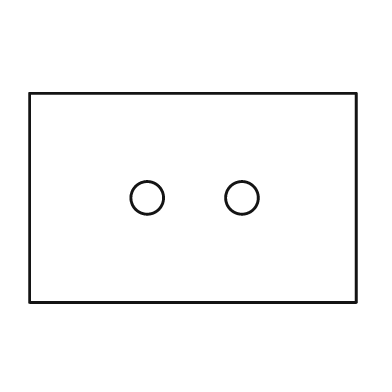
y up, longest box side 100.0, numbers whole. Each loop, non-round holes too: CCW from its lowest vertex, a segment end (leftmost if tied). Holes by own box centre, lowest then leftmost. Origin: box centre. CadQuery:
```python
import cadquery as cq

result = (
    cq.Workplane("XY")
    .moveTo(-50.0, -32.0)
    .lineTo(50.0, -32.0)
    .lineTo(50.0, 32.0)
    .lineTo(-50.0, 32.0)
    .close()
    .moveTo(-14.0, 0.0)
    .circle(5.0)
    .moveTo(15.0, 0.0)
    .circle(5.0)
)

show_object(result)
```